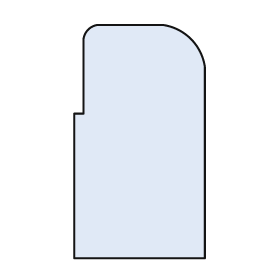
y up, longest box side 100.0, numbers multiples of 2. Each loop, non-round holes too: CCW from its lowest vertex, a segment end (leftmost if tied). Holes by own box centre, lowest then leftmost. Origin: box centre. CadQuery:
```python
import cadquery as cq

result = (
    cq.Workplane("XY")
    .moveTo(-28.0, -50.0)
    .lineTo(28.0, -50.0)
    .lineTo(28.0, 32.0)
    .threePointArc((22.0, 44.0), (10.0, 50.0))
    .lineTo(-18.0, 50.0)
    .threePointArc((-22.0, 48.0), (-24.0, 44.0))
    .lineTo(-24.0, 12.0)
    .lineTo(-28.0, 12.0)
    .close()
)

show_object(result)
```